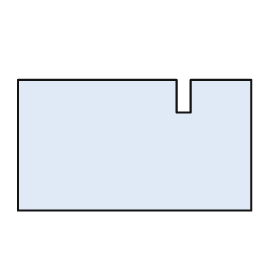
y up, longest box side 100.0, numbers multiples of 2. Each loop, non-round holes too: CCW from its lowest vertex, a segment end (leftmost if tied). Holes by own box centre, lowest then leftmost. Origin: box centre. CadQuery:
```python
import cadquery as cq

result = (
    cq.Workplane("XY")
    .moveTo(-50.0, -28.0)
    .lineTo(50.0, -28.0)
    .lineTo(50.0, 28.0)
    .lineTo(24.0, 28.0)
    .lineTo(24.0, 14.0)
    .lineTo(18.0, 14.0)
    .lineTo(18.0, 28.0)
    .lineTo(-50.0, 28.0)
    .close()
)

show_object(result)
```